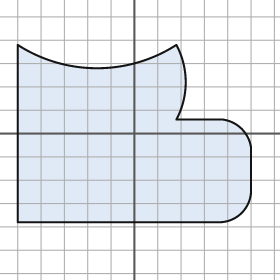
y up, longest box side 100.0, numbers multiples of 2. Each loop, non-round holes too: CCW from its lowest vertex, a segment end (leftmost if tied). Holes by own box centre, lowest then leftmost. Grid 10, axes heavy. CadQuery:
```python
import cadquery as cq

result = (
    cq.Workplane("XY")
    .moveTo(-50.0, -38.0)
    .lineTo(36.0, -38.0)
    .threePointArc((46.0, -34.0), (50.0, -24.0))
    .lineTo(50.0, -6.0)
    .threePointArc((46.0, 2.0), (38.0, 6.0))
    .lineTo(18.0, 6.0)
    .threePointArc((22.0, 22.0), (18.0, 38.0))
    .threePointArc((-16.0, 28.0), (-50.0, 38.0))
    .close()
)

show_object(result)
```